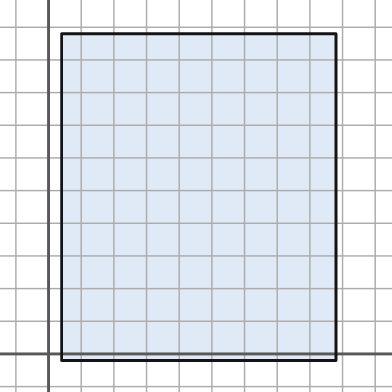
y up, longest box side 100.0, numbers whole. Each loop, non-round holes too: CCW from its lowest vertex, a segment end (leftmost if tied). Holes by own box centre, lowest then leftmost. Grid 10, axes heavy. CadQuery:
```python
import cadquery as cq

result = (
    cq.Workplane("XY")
    .moveTo(4.0, -2.0)
    .lineTo(88.0, -2.0)
    .lineTo(88.0, 98.0)
    .lineTo(4.0, 98.0)
    .close()
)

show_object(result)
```